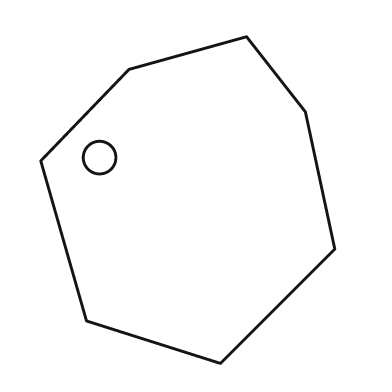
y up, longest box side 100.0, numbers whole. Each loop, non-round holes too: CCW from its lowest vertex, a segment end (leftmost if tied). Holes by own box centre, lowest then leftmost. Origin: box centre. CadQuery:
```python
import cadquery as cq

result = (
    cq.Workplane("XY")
    .moveTo(10.0, -50.0)
    .lineTo(45.0, -15.0)
    .lineTo(36.0, 27.0)
    .lineTo(18.0, 50.0)
    .lineTo(-18.0, 40.0)
    .lineTo(-45.0, 12.0)
    .lineTo(-31.0, -37.0)
    .close()
    .moveTo(-27.0, 13.0)
    .circle(5.0)
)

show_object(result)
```